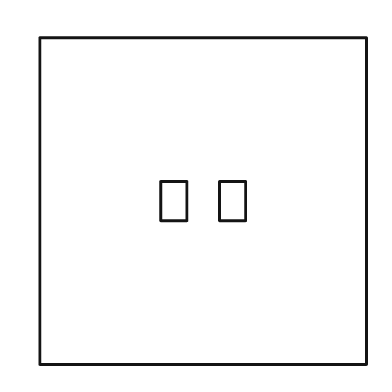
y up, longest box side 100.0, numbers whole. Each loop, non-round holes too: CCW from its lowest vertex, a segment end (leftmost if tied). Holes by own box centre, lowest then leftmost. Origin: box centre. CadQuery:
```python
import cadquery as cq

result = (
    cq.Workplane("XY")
    .moveTo(-50.0, -50.0)
    .lineTo(50.0, -50.0)
    .lineTo(50.0, 50.0)
    .lineTo(-50.0, 50.0)
    .close()
    .moveTo(-13.0, -6.0)
    .lineTo(-5.0, -6.0)
    .lineTo(-5.0, 6.0)
    .lineTo(-13.0, 6.0)
    .close()
    .moveTo(5.0, -6.0)
    .lineTo(13.0, -6.0)
    .lineTo(13.0, 6.0)
    .lineTo(5.0, 6.0)
    .close()
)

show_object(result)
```